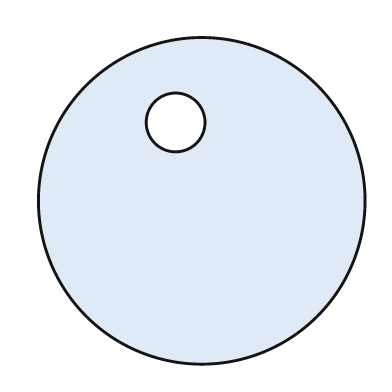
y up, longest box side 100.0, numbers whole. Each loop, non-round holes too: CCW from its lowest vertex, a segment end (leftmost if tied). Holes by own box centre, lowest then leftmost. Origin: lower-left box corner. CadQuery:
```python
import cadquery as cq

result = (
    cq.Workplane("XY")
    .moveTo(50.0, 50.0)
    .circle(50.0)
    .moveTo(42.0, 74.0)
    .circle(9.0)
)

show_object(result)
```